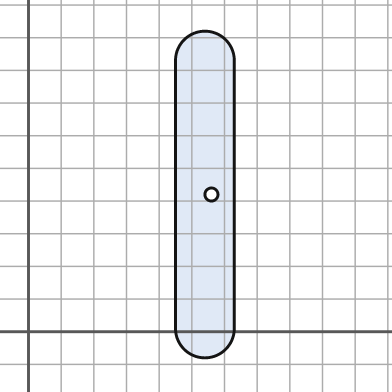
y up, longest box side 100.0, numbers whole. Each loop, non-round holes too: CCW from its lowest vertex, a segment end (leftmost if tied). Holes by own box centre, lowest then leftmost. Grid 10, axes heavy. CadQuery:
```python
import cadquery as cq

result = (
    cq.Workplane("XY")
    .moveTo(45.0, 1.0)
    .threePointArc((54.0, -8.0), (63.0, 1.0))
    .lineTo(63.0, 83.0)
    .threePointArc((54.0, 92.0), (45.0, 83.0))
    .close()
    .moveTo(56.0, 42.0)
    .circle(2.0)
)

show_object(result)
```